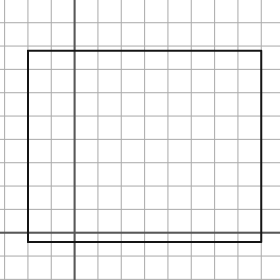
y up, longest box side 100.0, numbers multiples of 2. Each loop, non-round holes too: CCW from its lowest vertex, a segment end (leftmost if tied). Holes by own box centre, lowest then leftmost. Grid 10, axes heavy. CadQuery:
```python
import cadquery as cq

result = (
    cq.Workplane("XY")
    .moveTo(-20.0, -4.0)
    .lineTo(80.0, -4.0)
    .lineTo(80.0, 78.0)
    .lineTo(-20.0, 78.0)
    .close()
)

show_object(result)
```